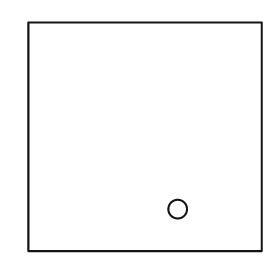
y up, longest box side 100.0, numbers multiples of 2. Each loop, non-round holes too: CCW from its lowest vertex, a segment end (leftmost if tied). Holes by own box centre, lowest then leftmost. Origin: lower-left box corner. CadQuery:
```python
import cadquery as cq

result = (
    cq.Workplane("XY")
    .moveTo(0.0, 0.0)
    .lineTo(100.0, 0.0)
    .lineTo(100.0, 98.0)
    .lineTo(0.0, 98.0)
    .close()
    .moveTo(64.0, 18.0)
    .circle(4.0)
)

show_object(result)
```